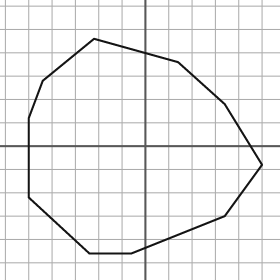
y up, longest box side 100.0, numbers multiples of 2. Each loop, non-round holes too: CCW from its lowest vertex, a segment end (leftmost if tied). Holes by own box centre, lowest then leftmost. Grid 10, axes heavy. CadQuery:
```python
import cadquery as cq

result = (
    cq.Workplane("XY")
    .moveTo(-24.0, -46.0)
    .lineTo(-6.0, -46.0)
    .lineTo(34.0, -30.0)
    .lineTo(50.0, -8.0)
    .lineTo(34.0, 18.0)
    .lineTo(14.0, 36.0)
    .lineTo(-22.0, 46.0)
    .lineTo(-44.0, 28.0)
    .lineTo(-50.0, 12.0)
    .lineTo(-50.0, -22.0)
    .close()
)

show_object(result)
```